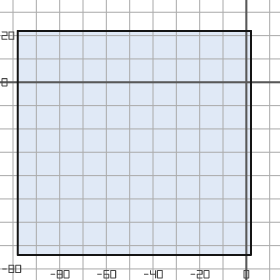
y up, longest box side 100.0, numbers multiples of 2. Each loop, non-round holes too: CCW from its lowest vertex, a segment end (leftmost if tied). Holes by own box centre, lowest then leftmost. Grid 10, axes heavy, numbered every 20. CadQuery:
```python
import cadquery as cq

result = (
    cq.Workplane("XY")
    .moveTo(-98.0, -74.0)
    .lineTo(2.0, -74.0)
    .lineTo(2.0, 22.0)
    .lineTo(-98.0, 22.0)
    .close()
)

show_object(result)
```